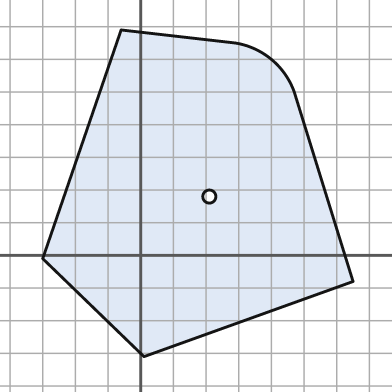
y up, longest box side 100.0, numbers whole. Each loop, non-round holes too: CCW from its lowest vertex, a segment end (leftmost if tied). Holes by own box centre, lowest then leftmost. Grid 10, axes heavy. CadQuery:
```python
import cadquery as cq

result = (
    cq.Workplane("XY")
    .moveTo(1.0, -31.0)
    .lineTo(65.0, -8.0)
    .lineTo(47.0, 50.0)
    .threePointArc((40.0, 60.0), (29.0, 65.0))
    .lineTo(-6.0, 69.0)
    .lineTo(-30.0, -1.0)
    .close()
    .moveTo(21.0, 18.0)
    .circle(2.0)
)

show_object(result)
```